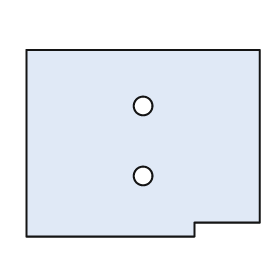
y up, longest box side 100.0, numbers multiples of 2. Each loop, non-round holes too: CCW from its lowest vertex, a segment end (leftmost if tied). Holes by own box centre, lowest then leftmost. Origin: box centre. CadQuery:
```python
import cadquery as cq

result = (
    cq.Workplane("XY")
    .moveTo(-50.0, -40.0)
    .lineTo(22.0, -40.0)
    .lineTo(22.0, -34.0)
    .lineTo(50.0, -34.0)
    .lineTo(50.0, 40.0)
    .lineTo(-50.0, 40.0)
    .close()
    .moveTo(0.0, -14.0)
    .circle(4.0)
    .moveTo(0.0, 16.0)
    .circle(4.0)
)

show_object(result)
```